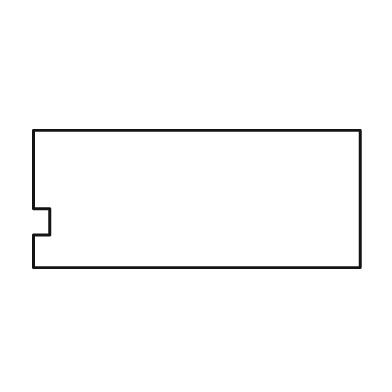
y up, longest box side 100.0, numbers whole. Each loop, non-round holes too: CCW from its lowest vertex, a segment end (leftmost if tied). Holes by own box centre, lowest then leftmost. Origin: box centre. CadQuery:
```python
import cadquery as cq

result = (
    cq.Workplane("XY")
    .moveTo(-50.0, -21.0)
    .lineTo(50.0, -21.0)
    .lineTo(50.0, 21.0)
    .lineTo(-50.0, 21.0)
    .lineTo(-50.0, -3.0)
    .lineTo(-45.0, -3.0)
    .lineTo(-45.0, -11.0)
    .lineTo(-50.0, -11.0)
    .close()
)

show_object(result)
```